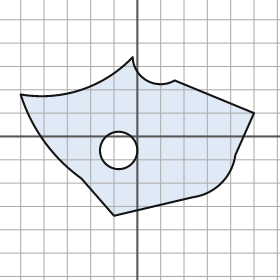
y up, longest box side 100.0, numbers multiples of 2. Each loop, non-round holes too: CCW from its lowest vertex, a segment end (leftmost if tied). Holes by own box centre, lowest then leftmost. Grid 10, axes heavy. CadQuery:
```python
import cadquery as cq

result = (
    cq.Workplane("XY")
    .moveTo(-10.0, -34.0)
    .lineTo(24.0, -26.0)
    .threePointArc((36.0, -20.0), (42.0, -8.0))
    .lineTo(50.0, 10.0)
    .lineTo(16.0, 24.0)
    .threePointArc((4.0, 24.0), (-2.0, 34.0))
    .threePointArc((-24.0, 20.0), (-50.0, 18.0))
    .threePointArc((-40.0, -2.0), (-24.0, -18.0))
    .close()
    .moveTo(-8.0, -6.0)
    .circle(8.0)
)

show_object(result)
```